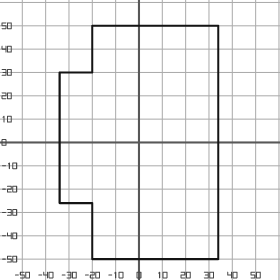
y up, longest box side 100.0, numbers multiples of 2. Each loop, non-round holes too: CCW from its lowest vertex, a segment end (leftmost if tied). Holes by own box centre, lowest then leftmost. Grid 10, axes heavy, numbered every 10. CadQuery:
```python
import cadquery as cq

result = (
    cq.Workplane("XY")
    .moveTo(-20.0, -50.0)
    .lineTo(34.0, -50.0)
    .lineTo(34.0, 50.0)
    .lineTo(-20.0, 50.0)
    .lineTo(-20.0, 30.0)
    .lineTo(-34.0, 30.0)
    .lineTo(-34.0, -26.0)
    .lineTo(-20.0, -26.0)
    .close()
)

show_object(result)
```